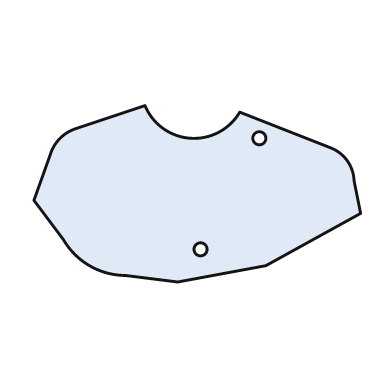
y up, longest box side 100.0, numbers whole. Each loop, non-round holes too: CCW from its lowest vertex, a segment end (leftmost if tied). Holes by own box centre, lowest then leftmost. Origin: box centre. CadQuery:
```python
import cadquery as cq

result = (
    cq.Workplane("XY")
    .moveTo(-6.0, -27.0)
    .lineTo(21.0, -22.0)
    .lineTo(50.0, -6.0)
    .lineTo(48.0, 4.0)
    .threePointArc((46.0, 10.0), (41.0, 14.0))
    .lineTo(13.0, 25.0)
    .threePointArc((-2.0, 17.0), (-16.0, 27.0))
    .lineTo(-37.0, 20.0)
    .threePointArc((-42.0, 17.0), (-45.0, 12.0))
    .lineTo(-50.0, -2.0)
    .lineTo(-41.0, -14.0)
    .threePointArc((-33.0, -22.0), (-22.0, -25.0))
    .close()
    .moveTo(1.0, -17.0)
    .circle(2.0)
    .moveTo(19.0, 17.0)
    .circle(2.0)
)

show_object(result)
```